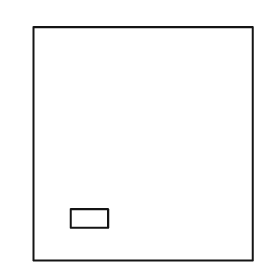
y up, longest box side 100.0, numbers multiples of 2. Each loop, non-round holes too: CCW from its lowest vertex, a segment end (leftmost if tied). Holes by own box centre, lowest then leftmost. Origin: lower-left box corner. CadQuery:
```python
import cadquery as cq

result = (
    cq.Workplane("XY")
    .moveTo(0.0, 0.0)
    .lineTo(94.0, 0.0)
    .lineTo(94.0, 100.0)
    .lineTo(0.0, 100.0)
    .close()
    .moveTo(16.0, 14.0)
    .lineTo(32.0, 14.0)
    .lineTo(32.0, 22.0)
    .lineTo(16.0, 22.0)
    .close()
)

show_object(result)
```